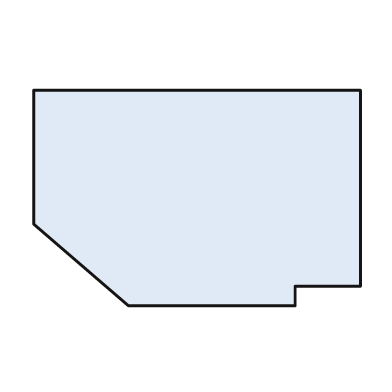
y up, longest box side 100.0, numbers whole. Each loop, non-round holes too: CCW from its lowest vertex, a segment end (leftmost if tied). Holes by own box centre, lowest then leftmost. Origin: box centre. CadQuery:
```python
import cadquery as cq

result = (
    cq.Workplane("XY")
    .moveTo(-21.0, -33.0)
    .lineTo(30.0, -33.0)
    .lineTo(30.0, -27.0)
    .lineTo(50.0, -27.0)
    .lineTo(50.0, 33.0)
    .lineTo(-50.0, 33.0)
    .lineTo(-50.0, -8.0)
    .close()
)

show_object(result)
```